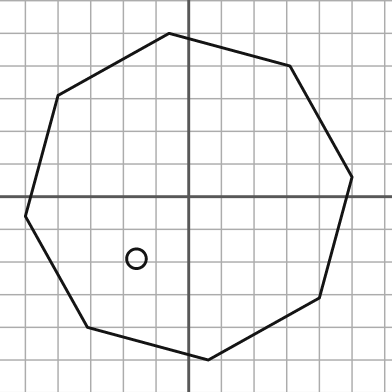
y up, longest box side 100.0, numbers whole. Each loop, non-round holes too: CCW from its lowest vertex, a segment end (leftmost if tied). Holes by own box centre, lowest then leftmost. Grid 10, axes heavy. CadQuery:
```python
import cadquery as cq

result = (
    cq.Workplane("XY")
    .moveTo(6.0, -50.0)
    .lineTo(40.0, -31.0)
    .lineTo(50.0, 6.0)
    .lineTo(31.0, 40.0)
    .lineTo(-6.0, 50.0)
    .lineTo(-40.0, 31.0)
    .lineTo(-50.0, -6.0)
    .lineTo(-31.0, -40.0)
    .close()
    .moveTo(-16.0, -19.0)
    .circle(3.0)
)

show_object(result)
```